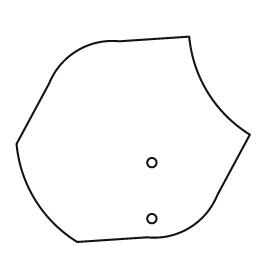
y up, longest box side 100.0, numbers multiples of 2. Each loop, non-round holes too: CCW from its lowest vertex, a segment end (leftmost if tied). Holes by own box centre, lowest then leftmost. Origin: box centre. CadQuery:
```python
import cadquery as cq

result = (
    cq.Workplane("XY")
    .moveTo(-24.0, -44.0)
    .lineTo(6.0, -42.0)
    .threePointArc((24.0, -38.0), (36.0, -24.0))
    .lineTo(50.0, 2.0)
    .threePointArc((32.0, 20.0), (24.0, 44.0))
    .lineTo(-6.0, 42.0)
    .threePointArc((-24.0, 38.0), (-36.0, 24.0))
    .lineTo(-50.0, -2.0)
    .threePointArc((-42.0, -26.0), (-24.0, -44.0))
    .close()
    .moveTo(8.0, -34.0)
    .circle(2.0)
    .moveTo(8.0, -10.0)
    .circle(2.0)
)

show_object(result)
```